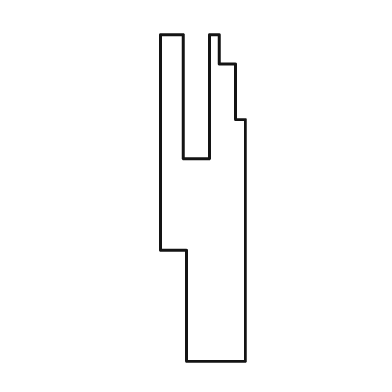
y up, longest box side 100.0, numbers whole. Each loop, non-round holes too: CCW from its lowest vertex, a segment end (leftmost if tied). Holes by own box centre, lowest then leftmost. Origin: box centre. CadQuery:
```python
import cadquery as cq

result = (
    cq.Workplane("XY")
    .moveTo(-5.0, -50.0)
    .lineTo(13.0, -50.0)
    .lineTo(13.0, 24.0)
    .lineTo(10.0, 24.0)
    .lineTo(10.0, 41.0)
    .lineTo(5.0, 41.0)
    .lineTo(5.0, 50.0)
    .lineTo(2.0, 50.0)
    .lineTo(2.0, 12.0)
    .lineTo(-6.0, 12.0)
    .lineTo(-6.0, 50.0)
    .lineTo(-13.0, 50.0)
    .lineTo(-13.0, -16.0)
    .lineTo(-5.0, -16.0)
    .close()
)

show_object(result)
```